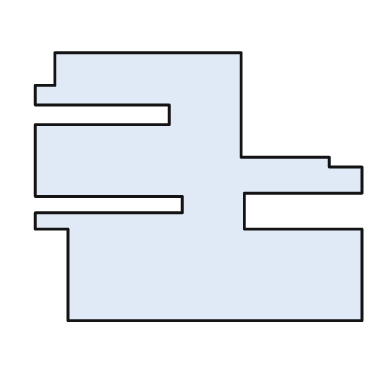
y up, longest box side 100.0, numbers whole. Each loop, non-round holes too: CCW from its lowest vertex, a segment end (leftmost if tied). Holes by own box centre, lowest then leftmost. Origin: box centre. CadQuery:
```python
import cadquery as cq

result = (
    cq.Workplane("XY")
    .moveTo(-40.0, -41.0)
    .lineTo(50.0, -41.0)
    .lineTo(50.0, -13.0)
    .lineTo(14.0, -13.0)
    .lineTo(14.0, -2.0)
    .lineTo(50.0, -2.0)
    .lineTo(50.0, 6.0)
    .lineTo(40.0, 6.0)
    .lineTo(40.0, 9.0)
    .lineTo(13.0, 9.0)
    .lineTo(13.0, 41.0)
    .lineTo(-44.0, 41.0)
    .lineTo(-44.0, 31.0)
    .lineTo(-50.0, 31.0)
    .lineTo(-50.0, 25.0)
    .lineTo(-9.0, 25.0)
    .lineTo(-9.0, 19.0)
    .lineTo(-50.0, 19.0)
    .lineTo(-50.0, -3.0)
    .lineTo(-5.0, -3.0)
    .lineTo(-5.0, -8.0)
    .lineTo(-50.0, -8.0)
    .lineTo(-50.0, -13.0)
    .lineTo(-40.0, -13.0)
    .close()
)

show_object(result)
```